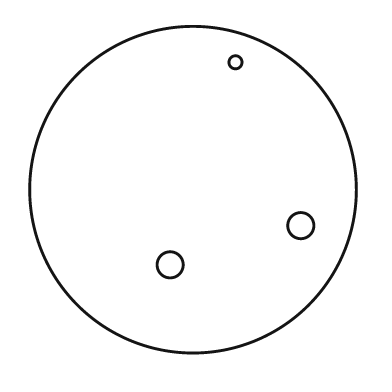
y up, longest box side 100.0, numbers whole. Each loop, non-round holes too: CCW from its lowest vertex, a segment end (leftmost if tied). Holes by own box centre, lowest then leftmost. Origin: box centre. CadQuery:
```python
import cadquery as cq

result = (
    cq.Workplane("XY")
    .moveTo(0.0, 0.0)
    .circle(50.0)
    .moveTo(-7.0, -23.0)
    .circle(4.0)
    .moveTo(33.0, -11.0)
    .circle(4.0)
    .moveTo(13.0, 39.0)
    .circle(2.0)
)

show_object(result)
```